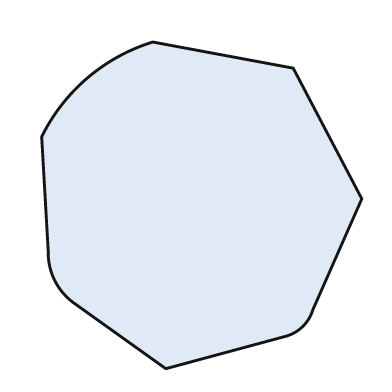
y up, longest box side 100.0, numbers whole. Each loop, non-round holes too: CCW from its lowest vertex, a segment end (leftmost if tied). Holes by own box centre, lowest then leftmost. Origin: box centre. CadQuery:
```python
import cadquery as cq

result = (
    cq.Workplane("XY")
    .moveTo(-11.0, -50.0)
    .lineTo(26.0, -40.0)
    .threePointArc((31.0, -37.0), (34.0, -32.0))
    .lineTo(49.0, 2.0)
    .lineTo(28.0, 42.0)
    .lineTo(-15.0, 50.0)
    .threePointArc((-35.0, 39.0), (-49.0, 21.0))
    .lineTo(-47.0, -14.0)
    .threePointArc((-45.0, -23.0), (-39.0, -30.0))
    .close()
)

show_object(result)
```